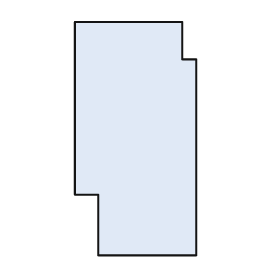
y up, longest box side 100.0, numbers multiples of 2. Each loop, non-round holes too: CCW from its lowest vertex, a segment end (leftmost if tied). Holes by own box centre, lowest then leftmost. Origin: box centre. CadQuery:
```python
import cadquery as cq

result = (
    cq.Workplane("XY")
    .moveTo(-16.0, -50.0)
    .lineTo(26.0, -50.0)
    .lineTo(26.0, 34.0)
    .lineTo(20.0, 34.0)
    .lineTo(20.0, 50.0)
    .lineTo(-26.0, 50.0)
    .lineTo(-26.0, -24.0)
    .lineTo(-16.0, -24.0)
    .close()
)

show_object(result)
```